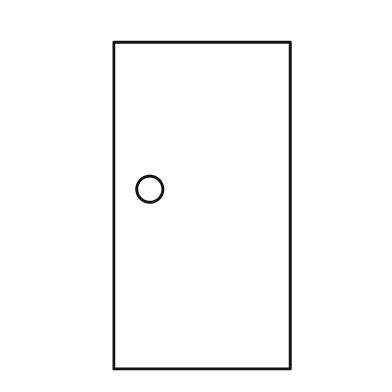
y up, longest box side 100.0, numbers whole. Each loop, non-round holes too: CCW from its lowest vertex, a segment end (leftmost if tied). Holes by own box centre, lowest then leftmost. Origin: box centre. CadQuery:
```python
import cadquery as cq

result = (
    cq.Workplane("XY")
    .moveTo(-27.0, -50.0)
    .lineTo(27.0, -50.0)
    .lineTo(27.0, 50.0)
    .lineTo(-27.0, 50.0)
    .close()
    .moveTo(-16.0, 5.0)
    .circle(4.0)
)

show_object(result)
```